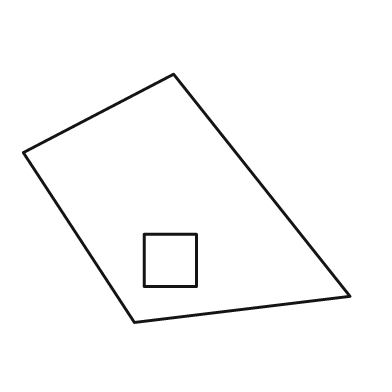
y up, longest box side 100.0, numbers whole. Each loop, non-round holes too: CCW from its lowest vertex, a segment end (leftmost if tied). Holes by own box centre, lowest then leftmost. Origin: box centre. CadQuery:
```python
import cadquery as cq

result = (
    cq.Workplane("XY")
    .moveTo(-16.0, -38.0)
    .lineTo(50.0, -30.0)
    .lineTo(-4.0, 38.0)
    .lineTo(-50.0, 14.0)
    .close()
    .moveTo(-13.0, -27.0)
    .lineTo(3.0, -27.0)
    .lineTo(3.0, -11.0)
    .lineTo(-13.0, -11.0)
    .close()
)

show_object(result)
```